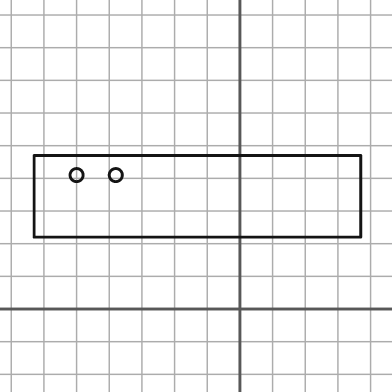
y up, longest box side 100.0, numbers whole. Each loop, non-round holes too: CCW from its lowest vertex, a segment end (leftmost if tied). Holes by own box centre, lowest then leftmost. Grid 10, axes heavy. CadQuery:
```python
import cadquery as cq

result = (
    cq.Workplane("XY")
    .moveTo(-63.0, 22.0)
    .lineTo(37.0, 22.0)
    .lineTo(37.0, 47.0)
    .lineTo(-63.0, 47.0)
    .close()
    .moveTo(-50.0, 41.0)
    .circle(2.0)
    .moveTo(-38.0, 41.0)
    .circle(2.0)
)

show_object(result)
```